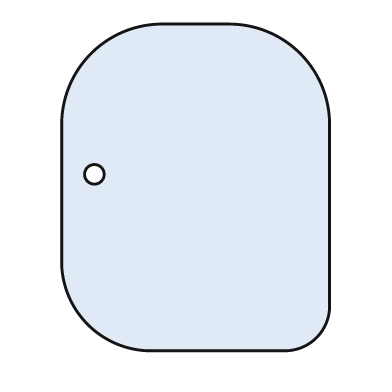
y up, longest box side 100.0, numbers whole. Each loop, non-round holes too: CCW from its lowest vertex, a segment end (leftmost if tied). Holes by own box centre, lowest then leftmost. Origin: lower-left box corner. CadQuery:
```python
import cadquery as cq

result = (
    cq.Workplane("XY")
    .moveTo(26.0, 0.0)
    .lineTo(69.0, 0.0)
    .threePointArc((78.0, 4.0), (82.0, 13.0))
    .lineTo(82.0, 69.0)
    .threePointArc((73.0, 91.0), (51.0, 100.0))
    .lineTo(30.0, 100.0)
    .threePointArc((9.0, 91.0), (0.0, 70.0))
    .lineTo(0.0, 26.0)
    .threePointArc((8.0, 8.0), (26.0, 0.0))
    .close()
    .moveTo(10.0, 54.0)
    .circle(3.0)
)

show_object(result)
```